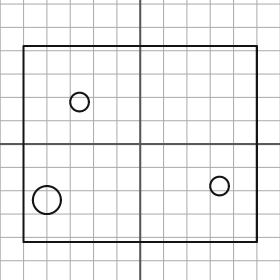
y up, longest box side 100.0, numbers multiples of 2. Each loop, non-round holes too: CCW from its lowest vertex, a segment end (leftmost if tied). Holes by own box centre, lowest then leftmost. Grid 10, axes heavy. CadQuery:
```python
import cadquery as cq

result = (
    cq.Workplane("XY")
    .moveTo(-50.0, -42.0)
    .lineTo(50.0, -42.0)
    .lineTo(50.0, 42.0)
    .lineTo(-50.0, 42.0)
    .close()
    .moveTo(-40.0, -24.0)
    .circle(6.0)
    .moveTo(34.0, -18.0)
    .circle(4.0)
    .moveTo(-26.0, 18.0)
    .circle(4.0)
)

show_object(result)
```